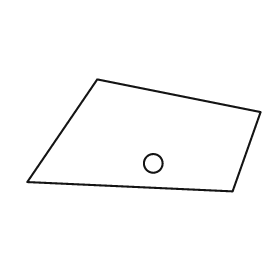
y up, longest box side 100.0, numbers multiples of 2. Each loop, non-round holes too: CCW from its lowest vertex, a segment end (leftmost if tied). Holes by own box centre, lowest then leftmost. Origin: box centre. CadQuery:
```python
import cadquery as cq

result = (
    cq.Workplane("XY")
    .moveTo(38.0, -24.0)
    .lineTo(50.0, 10.0)
    .lineTo(-20.0, 24.0)
    .lineTo(-50.0, -20.0)
    .close()
    .moveTo(4.0, -12.0)
    .circle(4.0)
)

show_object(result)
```